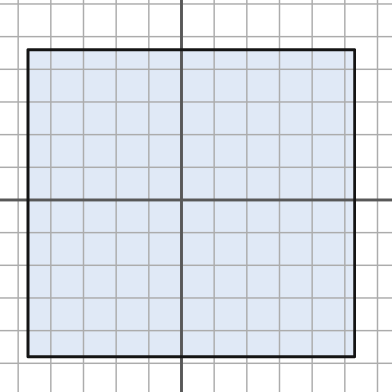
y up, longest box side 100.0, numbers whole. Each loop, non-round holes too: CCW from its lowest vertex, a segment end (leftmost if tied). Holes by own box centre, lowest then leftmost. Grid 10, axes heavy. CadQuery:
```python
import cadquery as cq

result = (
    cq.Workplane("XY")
    .moveTo(-47.0, -48.0)
    .lineTo(53.0, -48.0)
    .lineTo(53.0, 46.0)
    .lineTo(-47.0, 46.0)
    .close()
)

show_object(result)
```